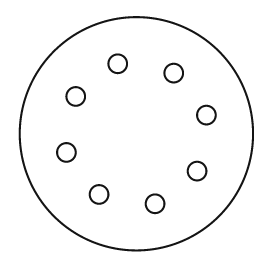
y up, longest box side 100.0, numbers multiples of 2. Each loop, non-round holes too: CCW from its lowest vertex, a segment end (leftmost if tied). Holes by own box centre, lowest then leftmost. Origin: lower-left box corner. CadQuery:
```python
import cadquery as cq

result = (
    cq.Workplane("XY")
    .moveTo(50.0, 50.0)
    .circle(50.0)
    .moveTo(58.0, 20.0)
    .circle(4.0)
    .moveTo(34.0, 24.0)
    .circle(4.0)
    .moveTo(76.0, 34.0)
    .circle(4.0)
    .moveTo(20.0, 42.0)
    .circle(4.0)
    .moveTo(80.0, 58.0)
    .circle(4.0)
    .moveTo(24.0, 66.0)
    .circle(4.0)
    .moveTo(66.0, 76.0)
    .circle(4.0)
    .moveTo(42.0, 80.0)
    .circle(4.0)
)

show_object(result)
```